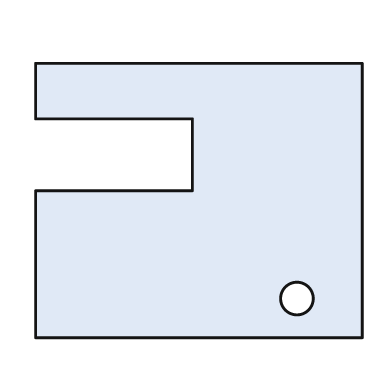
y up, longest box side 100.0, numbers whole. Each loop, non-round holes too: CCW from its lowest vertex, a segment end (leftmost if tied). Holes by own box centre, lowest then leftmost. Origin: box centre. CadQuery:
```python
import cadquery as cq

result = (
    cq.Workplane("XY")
    .moveTo(-50.0, -42.0)
    .lineTo(50.0, -42.0)
    .lineTo(50.0, 42.0)
    .lineTo(-50.0, 42.0)
    .lineTo(-50.0, 25.0)
    .lineTo(-2.0, 25.0)
    .lineTo(-2.0, 3.0)
    .lineTo(-50.0, 3.0)
    .close()
    .moveTo(30.0, -30.0)
    .circle(5.0)
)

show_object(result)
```